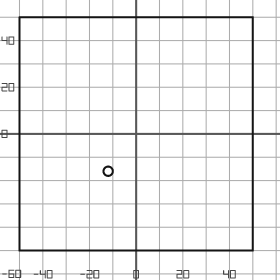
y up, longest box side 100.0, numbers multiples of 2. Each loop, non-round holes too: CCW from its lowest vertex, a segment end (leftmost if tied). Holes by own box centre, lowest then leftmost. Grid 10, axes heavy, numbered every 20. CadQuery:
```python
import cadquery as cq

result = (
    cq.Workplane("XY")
    .moveTo(-50.0, -50.0)
    .lineTo(50.0, -50.0)
    .lineTo(50.0, 50.0)
    .lineTo(-50.0, 50.0)
    .close()
    .moveTo(-12.0, -16.0)
    .circle(2.0)
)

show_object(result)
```